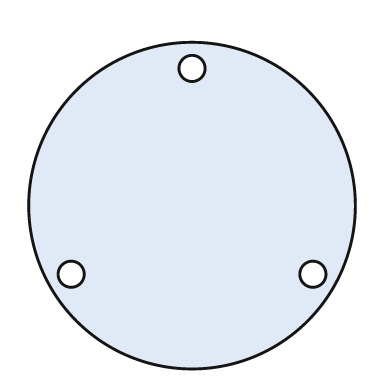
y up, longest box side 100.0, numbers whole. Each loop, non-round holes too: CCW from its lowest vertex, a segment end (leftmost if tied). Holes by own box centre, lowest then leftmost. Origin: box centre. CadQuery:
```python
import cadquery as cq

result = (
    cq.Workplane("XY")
    .moveTo(0.0, 0.0)
    .circle(50.0)
    .moveTo(-37.0, -21.0)
    .circle(4.0)
    .moveTo(37.0, -21.0)
    .circle(4.0)
    .moveTo(0.0, 42.0)
    .circle(4.0)
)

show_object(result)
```